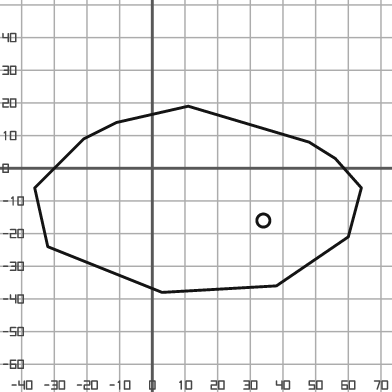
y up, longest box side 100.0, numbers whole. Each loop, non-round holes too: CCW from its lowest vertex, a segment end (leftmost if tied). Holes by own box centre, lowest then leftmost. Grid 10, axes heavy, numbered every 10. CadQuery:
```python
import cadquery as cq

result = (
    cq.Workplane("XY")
    .moveTo(3.0, -38.0)
    .lineTo(38.0, -36.0)
    .lineTo(60.0, -21.0)
    .lineTo(64.0, -6.0)
    .lineTo(56.0, 3.0)
    .lineTo(48.0, 8.0)
    .lineTo(11.0, 19.0)
    .lineTo(-11.0, 14.0)
    .lineTo(-21.0, 9.0)
    .lineTo(-36.0, -6.0)
    .lineTo(-32.0, -24.0)
    .close()
    .moveTo(34.0, -16.0)
    .circle(2.0)
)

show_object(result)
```